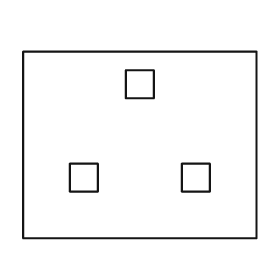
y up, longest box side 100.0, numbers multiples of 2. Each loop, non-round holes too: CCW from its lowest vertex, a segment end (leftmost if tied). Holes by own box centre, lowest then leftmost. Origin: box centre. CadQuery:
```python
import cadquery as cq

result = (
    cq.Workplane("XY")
    .moveTo(-50.0, -40.0)
    .lineTo(50.0, -40.0)
    .lineTo(50.0, 40.0)
    .lineTo(-50.0, 40.0)
    .close()
    .moveTo(-30.0, -20.0)
    .lineTo(-18.0, -20.0)
    .lineTo(-18.0, -8.0)
    .lineTo(-30.0, -8.0)
    .close()
    .moveTo(18.0, -20.0)
    .lineTo(30.0, -20.0)
    .lineTo(30.0, -8.0)
    .lineTo(18.0, -8.0)
    .close()
    .moveTo(-6.0, 20.0)
    .lineTo(6.0, 20.0)
    .lineTo(6.0, 32.0)
    .lineTo(-6.0, 32.0)
    .close()
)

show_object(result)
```